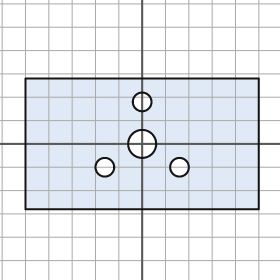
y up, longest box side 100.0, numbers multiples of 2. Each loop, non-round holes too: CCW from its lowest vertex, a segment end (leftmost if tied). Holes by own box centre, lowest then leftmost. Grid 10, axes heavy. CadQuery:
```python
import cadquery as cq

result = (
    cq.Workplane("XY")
    .moveTo(-50.0, -28.0)
    .lineTo(50.0, -28.0)
    .lineTo(50.0, 28.0)
    .lineTo(-50.0, 28.0)
    .close()
    .moveTo(-16.0, -10.0)
    .circle(4.0)
    .moveTo(16.0, -10.0)
    .circle(4.0)
    .moveTo(0.0, 0.0)
    .circle(6.0)
    .moveTo(0.0, 18.0)
    .circle(4.0)
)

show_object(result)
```